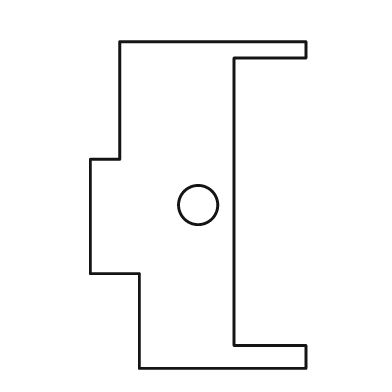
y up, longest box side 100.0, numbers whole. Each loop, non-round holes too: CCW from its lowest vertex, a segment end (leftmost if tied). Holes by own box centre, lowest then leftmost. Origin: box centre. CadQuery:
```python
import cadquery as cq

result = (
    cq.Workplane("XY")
    .moveTo(-18.0, -50.0)
    .lineTo(33.0, -50.0)
    .lineTo(33.0, -43.0)
    .lineTo(11.0, -43.0)
    .lineTo(11.0, 45.0)
    .lineTo(33.0, 45.0)
    .lineTo(33.0, 50.0)
    .lineTo(-24.0, 50.0)
    .lineTo(-24.0, 14.0)
    .lineTo(-33.0, 14.0)
    .lineTo(-33.0, -21.0)
    .lineTo(-18.0, -21.0)
    .close()
    .moveTo(0.0, 0.0)
    .circle(6.0)
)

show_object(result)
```